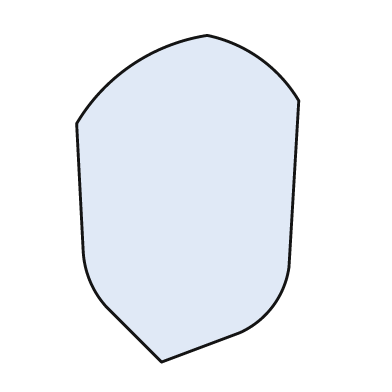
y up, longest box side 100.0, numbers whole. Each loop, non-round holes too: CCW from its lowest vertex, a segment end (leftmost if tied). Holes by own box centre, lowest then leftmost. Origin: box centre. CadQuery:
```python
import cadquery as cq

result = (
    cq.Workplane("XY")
    .moveTo(-8.0, -50.0)
    .lineTo(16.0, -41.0)
    .threePointArc((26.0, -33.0), (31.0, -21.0))
    .lineTo(34.0, 30.0)
    .threePointArc((22.0, 43.0), (6.0, 50.0))
    .threePointArc((-17.0, 41.0), (-34.0, 23.0))
    .lineTo(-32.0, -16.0)
    .threePointArc((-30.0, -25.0), (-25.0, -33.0))
    .close()
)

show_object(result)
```